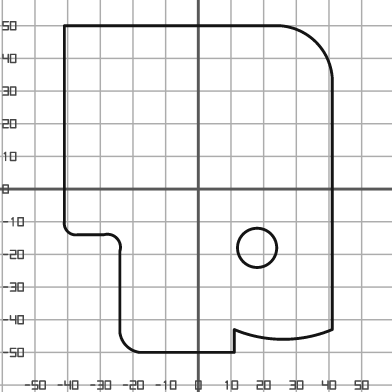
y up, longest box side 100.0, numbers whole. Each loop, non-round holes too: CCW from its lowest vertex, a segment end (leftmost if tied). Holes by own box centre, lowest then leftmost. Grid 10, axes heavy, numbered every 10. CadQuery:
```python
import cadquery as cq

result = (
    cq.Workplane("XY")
    .moveTo(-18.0, -50.0)
    .lineTo(11.0, -50.0)
    .lineTo(11.0, -43.0)
    .threePointArc((26.0, -46.0), (41.0, -43.0))
    .lineTo(41.0, 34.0)
    .threePointArc((36.0, 45.0), (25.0, 50.0))
    .lineTo(-41.0, 50.0)
    .lineTo(-41.0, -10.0)
    .threePointArc((-40.0, -13.0), (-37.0, -14.0))
    .lineTo(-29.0, -14.0)
    .threePointArc((-25.0, -15.0), (-24.0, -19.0))
    .lineTo(-24.0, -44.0)
    .threePointArc((-22.0, -48.0), (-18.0, -50.0))
    .close()
    .moveTo(18.0, -18.0)
    .circle(6.0)
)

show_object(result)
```